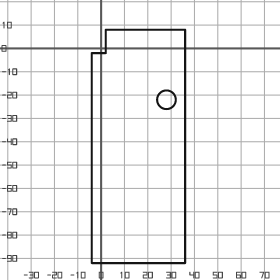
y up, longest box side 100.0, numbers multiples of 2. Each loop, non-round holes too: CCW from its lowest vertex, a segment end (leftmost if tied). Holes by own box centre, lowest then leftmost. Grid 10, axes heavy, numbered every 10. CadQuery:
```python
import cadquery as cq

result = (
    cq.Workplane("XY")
    .moveTo(-4.0, -92.0)
    .lineTo(36.0, -92.0)
    .lineTo(36.0, 8.0)
    .lineTo(2.0, 8.0)
    .lineTo(2.0, -2.0)
    .lineTo(-4.0, -2.0)
    .close()
    .moveTo(28.0, -22.0)
    .circle(4.0)
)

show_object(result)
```